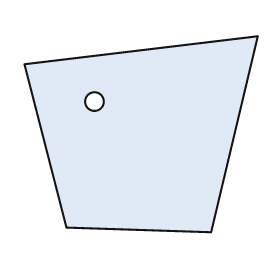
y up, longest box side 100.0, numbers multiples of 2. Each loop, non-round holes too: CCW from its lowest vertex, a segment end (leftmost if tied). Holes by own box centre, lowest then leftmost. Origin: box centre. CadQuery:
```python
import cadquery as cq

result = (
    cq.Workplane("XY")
    .moveTo(30.0, -42.0)
    .lineTo(50.0, 42.0)
    .lineTo(-50.0, 30.0)
    .lineTo(-32.0, -40.0)
    .close()
    .moveTo(-20.0, 14.0)
    .circle(4.0)
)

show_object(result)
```